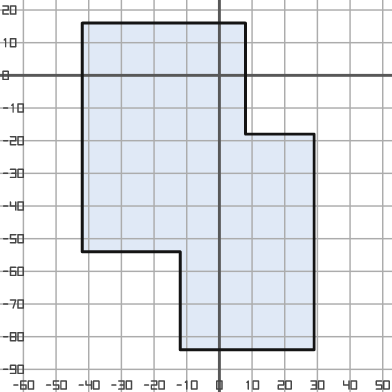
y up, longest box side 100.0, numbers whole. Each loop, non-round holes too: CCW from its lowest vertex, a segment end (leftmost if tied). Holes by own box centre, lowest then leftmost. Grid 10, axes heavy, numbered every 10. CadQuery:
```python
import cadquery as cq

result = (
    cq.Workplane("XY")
    .moveTo(-12.0, -84.0)
    .lineTo(29.0, -84.0)
    .lineTo(29.0, -18.0)
    .lineTo(8.0, -18.0)
    .lineTo(8.0, 16.0)
    .lineTo(-42.0, 16.0)
    .lineTo(-42.0, -54.0)
    .lineTo(-12.0, -54.0)
    .close()
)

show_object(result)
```